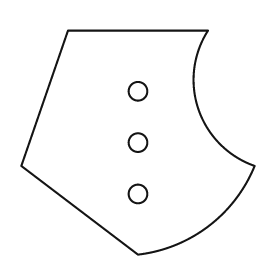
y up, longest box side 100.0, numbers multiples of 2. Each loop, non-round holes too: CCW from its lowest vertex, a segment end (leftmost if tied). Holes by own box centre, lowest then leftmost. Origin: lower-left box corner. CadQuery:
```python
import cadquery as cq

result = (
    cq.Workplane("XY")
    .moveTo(50.0, 0.0)
    .threePointArc((80.0, 12.0), (100.0, 38.0))
    .threePointArc((76.0, 62.0), (80.0, 96.0))
    .lineTo(20.0, 96.0)
    .lineTo(0.0, 38.0)
    .close()
    .moveTo(50.0, 26.0)
    .circle(4.0)
    .moveTo(50.0, 48.0)
    .circle(4.0)
    .moveTo(50.0, 70.0)
    .circle(4.0)
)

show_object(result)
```